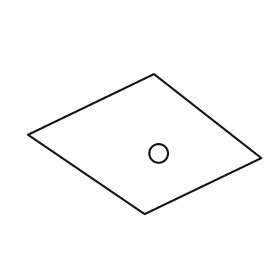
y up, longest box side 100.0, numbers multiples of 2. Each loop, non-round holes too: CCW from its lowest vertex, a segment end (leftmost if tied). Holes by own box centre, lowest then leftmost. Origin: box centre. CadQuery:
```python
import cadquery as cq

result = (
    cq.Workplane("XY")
    .moveTo(0.0, -30.0)
    .lineTo(50.0, -6.0)
    .lineTo(4.0, 30.0)
    .lineTo(-50.0, 4.0)
    .close()
    .moveTo(6.0, -4.0)
    .circle(4.0)
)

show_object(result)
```